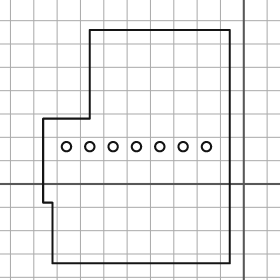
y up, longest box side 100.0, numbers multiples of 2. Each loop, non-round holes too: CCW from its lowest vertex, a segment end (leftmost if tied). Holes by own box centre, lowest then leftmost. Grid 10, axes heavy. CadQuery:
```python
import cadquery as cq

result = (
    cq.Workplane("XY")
    .moveTo(-82.0, -34.0)
    .lineTo(-6.0, -34.0)
    .lineTo(-6.0, 66.0)
    .lineTo(-66.0, 66.0)
    .lineTo(-66.0, 28.0)
    .lineTo(-86.0, 28.0)
    .lineTo(-86.0, -8.0)
    .lineTo(-82.0, -8.0)
    .close()
    .moveTo(-76.0, 16.0)
    .circle(2.0)
    .moveTo(-66.0, 16.0)
    .circle(2.0)
    .moveTo(-56.0, 16.0)
    .circle(2.0)
    .moveTo(-46.0, 16.0)
    .circle(2.0)
    .moveTo(-36.0, 16.0)
    .circle(2.0)
    .moveTo(-26.0, 16.0)
    .circle(2.0)
    .moveTo(-16.0, 16.0)
    .circle(2.0)
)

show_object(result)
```